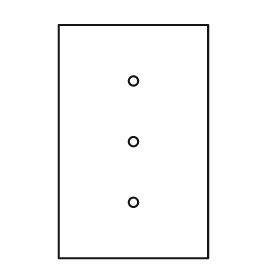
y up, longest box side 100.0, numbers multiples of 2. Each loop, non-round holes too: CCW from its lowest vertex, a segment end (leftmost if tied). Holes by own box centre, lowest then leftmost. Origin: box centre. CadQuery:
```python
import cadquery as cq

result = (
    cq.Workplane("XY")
    .moveTo(-32.0, -50.0)
    .lineTo(32.0, -50.0)
    .lineTo(32.0, 50.0)
    .lineTo(-32.0, 50.0)
    .close()
    .moveTo(0.0, -26.0)
    .circle(2.0)
    .moveTo(0.0, 0.0)
    .circle(2.0)
    .moveTo(0.0, 26.0)
    .circle(2.0)
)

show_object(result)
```